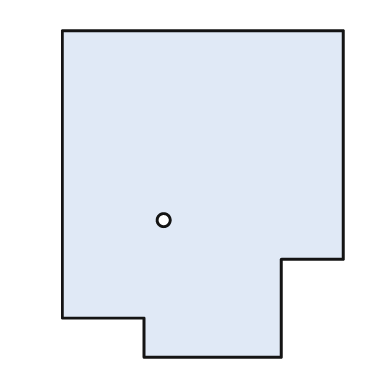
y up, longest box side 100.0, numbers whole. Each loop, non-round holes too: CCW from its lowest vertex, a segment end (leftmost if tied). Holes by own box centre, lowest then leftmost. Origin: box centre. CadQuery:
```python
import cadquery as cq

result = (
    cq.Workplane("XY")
    .moveTo(-18.0, -50.0)
    .lineTo(24.0, -50.0)
    .lineTo(24.0, -20.0)
    .lineTo(43.0, -20.0)
    .lineTo(43.0, 50.0)
    .lineTo(-43.0, 50.0)
    .lineTo(-43.0, -38.0)
    .lineTo(-18.0, -38.0)
    .close()
    .moveTo(-12.0, -8.0)
    .circle(2.0)
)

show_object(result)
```